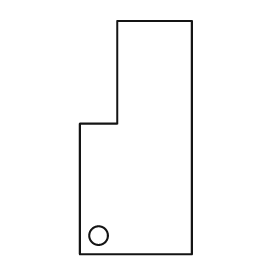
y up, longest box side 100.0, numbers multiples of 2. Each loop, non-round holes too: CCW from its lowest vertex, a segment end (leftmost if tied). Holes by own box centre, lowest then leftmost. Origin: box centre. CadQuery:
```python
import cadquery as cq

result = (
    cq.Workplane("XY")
    .moveTo(-24.0, -50.0)
    .lineTo(24.0, -50.0)
    .lineTo(24.0, 50.0)
    .lineTo(-8.0, 50.0)
    .lineTo(-8.0, 6.0)
    .lineTo(-24.0, 6.0)
    .close()
    .moveTo(-16.0, -42.0)
    .circle(4.0)
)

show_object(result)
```